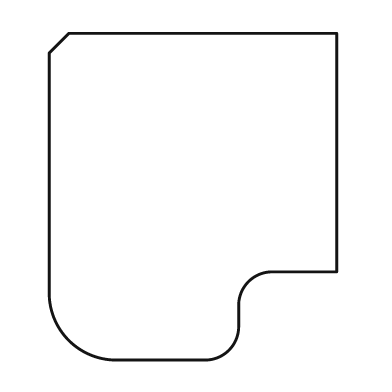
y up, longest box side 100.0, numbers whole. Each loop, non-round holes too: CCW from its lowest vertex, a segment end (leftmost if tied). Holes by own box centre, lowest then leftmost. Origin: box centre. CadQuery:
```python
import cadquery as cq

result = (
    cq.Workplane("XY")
    .moveTo(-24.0, -50.0)
    .lineTo(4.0, -50.0)
    .threePointArc((11.0, -47.0), (14.0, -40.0))
    .lineTo(14.0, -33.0)
    .threePointArc((17.0, -26.0), (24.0, -23.0))
    .lineTo(44.0, -23.0)
    .lineTo(44.0, 50.0)
    .lineTo(-38.0, 50.0)
    .lineTo(-44.0, 44.0)
    .lineTo(-44.0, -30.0)
    .threePointArc((-38.0, -44.0), (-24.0, -50.0))
    .close()
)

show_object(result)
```